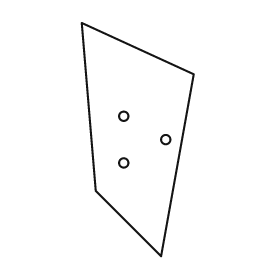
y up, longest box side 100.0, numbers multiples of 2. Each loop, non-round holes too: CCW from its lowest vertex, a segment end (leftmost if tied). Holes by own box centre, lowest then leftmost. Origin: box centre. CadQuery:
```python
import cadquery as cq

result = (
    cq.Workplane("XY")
    .moveTo(10.0, -50.0)
    .lineTo(24.0, 28.0)
    .lineTo(-24.0, 50.0)
    .lineTo(-18.0, -22.0)
    .close()
    .moveTo(-6.0, -10.0)
    .circle(2.0)
    .moveTo(12.0, 0.0)
    .circle(2.0)
    .moveTo(-6.0, 10.0)
    .circle(2.0)
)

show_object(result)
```